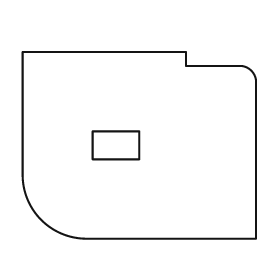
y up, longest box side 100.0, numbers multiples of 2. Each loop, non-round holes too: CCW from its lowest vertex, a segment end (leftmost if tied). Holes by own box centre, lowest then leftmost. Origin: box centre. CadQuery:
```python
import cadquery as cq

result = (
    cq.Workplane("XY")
    .moveTo(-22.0, -40.0)
    .lineTo(50.0, -40.0)
    .lineTo(50.0, 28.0)
    .threePointArc((48.0, 32.0), (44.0, 34.0))
    .lineTo(20.0, 34.0)
    .lineTo(20.0, 40.0)
    .lineTo(-50.0, 40.0)
    .lineTo(-50.0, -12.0)
    .threePointArc((-42.0, -32.0), (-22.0, -40.0))
    .close()
    .moveTo(-20.0, -6.0)
    .lineTo(0.0, -6.0)
    .lineTo(0.0, 6.0)
    .lineTo(-20.0, 6.0)
    .close()
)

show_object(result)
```